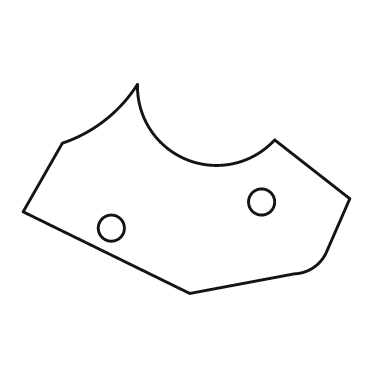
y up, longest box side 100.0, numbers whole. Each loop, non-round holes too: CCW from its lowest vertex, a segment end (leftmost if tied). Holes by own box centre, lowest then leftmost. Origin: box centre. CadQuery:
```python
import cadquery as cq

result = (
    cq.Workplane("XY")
    .moveTo(1.0, -32.0)
    .lineTo(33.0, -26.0)
    .threePointArc((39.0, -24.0), (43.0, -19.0))
    .lineTo(50.0, -3.0)
    .lineTo(27.0, 15.0)
    .threePointArc((0.0, 9.0), (-15.0, 32.0))
    .threePointArc((-25.0, 21.0), (-38.0, 14.0))
    .lineTo(-50.0, -7.0)
    .close()
    .moveTo(-23.0, -12.0)
    .circle(4.0)
    .moveTo(23.0, -4.0)
    .circle(4.0)
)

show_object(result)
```